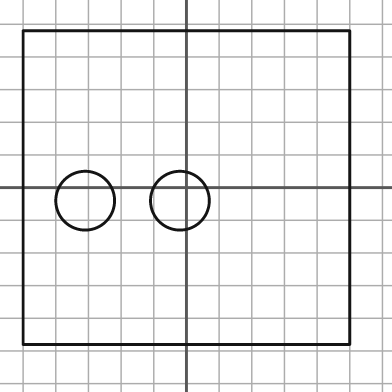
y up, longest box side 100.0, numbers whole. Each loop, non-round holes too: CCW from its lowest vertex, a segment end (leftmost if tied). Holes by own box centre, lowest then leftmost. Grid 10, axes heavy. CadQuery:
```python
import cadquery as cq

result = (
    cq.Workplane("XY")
    .moveTo(-50.0, -48.0)
    .lineTo(50.0, -48.0)
    .lineTo(50.0, 48.0)
    .lineTo(-50.0, 48.0)
    .close()
    .moveTo(-31.0, -4.0)
    .circle(9.0)
    .moveTo(-2.0, -4.0)
    .circle(9.0)
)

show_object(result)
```